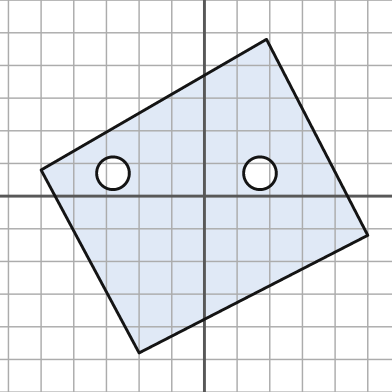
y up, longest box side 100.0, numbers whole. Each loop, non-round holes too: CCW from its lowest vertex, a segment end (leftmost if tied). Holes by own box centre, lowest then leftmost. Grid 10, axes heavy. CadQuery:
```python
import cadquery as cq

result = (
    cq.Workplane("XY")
    .moveTo(-20.0, -48.0)
    .lineTo(50.0, -12.0)
    .lineTo(19.0, 48.0)
    .lineTo(-50.0, 8.0)
    .close()
    .moveTo(-28.0, 7.0)
    .circle(5.0)
    .moveTo(17.0, 7.0)
    .circle(5.0)
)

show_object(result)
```